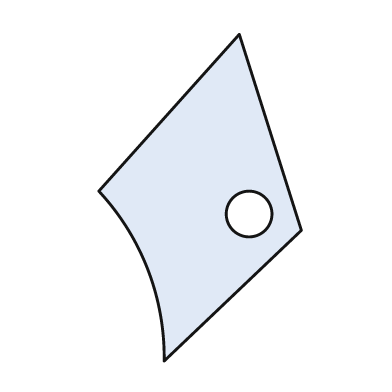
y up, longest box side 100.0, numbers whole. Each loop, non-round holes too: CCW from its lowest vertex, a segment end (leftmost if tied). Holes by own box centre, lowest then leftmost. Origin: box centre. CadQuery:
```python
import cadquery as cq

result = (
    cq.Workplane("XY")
    .moveTo(-11.0, -50.0)
    .lineTo(31.0, -10.0)
    .lineTo(12.0, 50.0)
    .lineTo(-31.0, 2.0)
    .threePointArc((-16.0, -22.0), (-11.0, -50.0))
    .close()
    .moveTo(15.0, -5.0)
    .circle(7.0)
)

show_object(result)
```